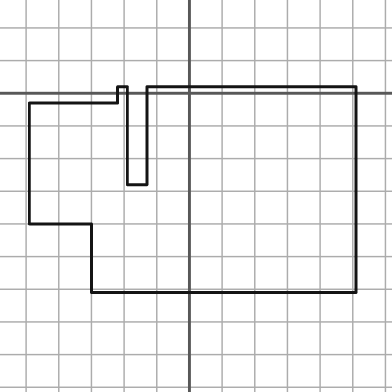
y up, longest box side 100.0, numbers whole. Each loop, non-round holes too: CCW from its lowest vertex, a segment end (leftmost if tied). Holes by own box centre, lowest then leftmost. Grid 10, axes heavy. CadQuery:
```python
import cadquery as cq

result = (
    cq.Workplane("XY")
    .moveTo(-30.0, -61.0)
    .lineTo(51.0, -61.0)
    .lineTo(51.0, 2.0)
    .lineTo(-13.0, 2.0)
    .lineTo(-13.0, -28.0)
    .lineTo(-19.0, -28.0)
    .lineTo(-19.0, 2.0)
    .lineTo(-22.0, 2.0)
    .lineTo(-22.0, -3.0)
    .lineTo(-49.0, -3.0)
    .lineTo(-49.0, -40.0)
    .lineTo(-30.0, -40.0)
    .close()
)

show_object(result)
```